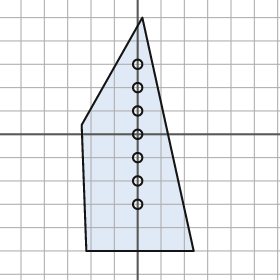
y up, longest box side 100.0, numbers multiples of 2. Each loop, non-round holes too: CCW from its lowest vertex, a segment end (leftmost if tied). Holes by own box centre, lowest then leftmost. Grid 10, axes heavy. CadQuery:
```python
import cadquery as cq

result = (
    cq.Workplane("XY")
    .moveTo(-22.0, -50.0)
    .lineTo(24.0, -50.0)
    .lineTo(2.0, 50.0)
    .lineTo(-24.0, 4.0)
    .close()
    .moveTo(0.0, -30.0)
    .circle(2.0)
    .moveTo(0.0, -20.0)
    .circle(2.0)
    .moveTo(0.0, -10.0)
    .circle(2.0)
    .moveTo(0.0, 0.0)
    .circle(2.0)
    .moveTo(0.0, 10.0)
    .circle(2.0)
    .moveTo(0.0, 20.0)
    .circle(2.0)
    .moveTo(0.0, 30.0)
    .circle(2.0)
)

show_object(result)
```